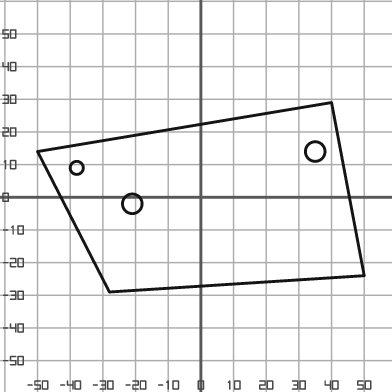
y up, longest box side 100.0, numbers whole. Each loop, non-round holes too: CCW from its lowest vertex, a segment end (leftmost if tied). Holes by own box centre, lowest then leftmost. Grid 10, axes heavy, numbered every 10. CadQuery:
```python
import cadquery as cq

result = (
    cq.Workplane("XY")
    .moveTo(-28.0, -29.0)
    .lineTo(50.0, -24.0)
    .lineTo(40.0, 29.0)
    .lineTo(-50.0, 14.0)
    .close()
    .moveTo(-21.0, -2.0)
    .circle(3.0)
    .moveTo(-38.0, 9.0)
    .circle(2.0)
    .moveTo(35.0, 14.0)
    .circle(3.0)
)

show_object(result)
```